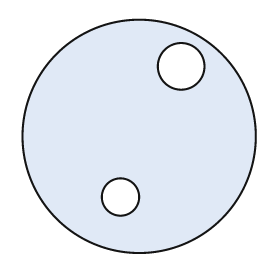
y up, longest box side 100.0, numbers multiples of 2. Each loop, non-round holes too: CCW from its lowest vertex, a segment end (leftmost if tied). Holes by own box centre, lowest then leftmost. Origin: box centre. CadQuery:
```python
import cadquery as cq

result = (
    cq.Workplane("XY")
    .moveTo(0.0, 0.0)
    .circle(50.0)
    .moveTo(-8.0, -26.0)
    .circle(8.0)
    .moveTo(18.0, 30.0)
    .circle(10.0)
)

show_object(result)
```